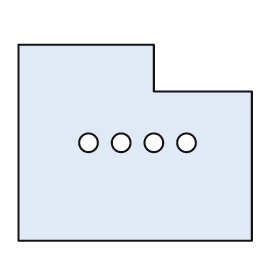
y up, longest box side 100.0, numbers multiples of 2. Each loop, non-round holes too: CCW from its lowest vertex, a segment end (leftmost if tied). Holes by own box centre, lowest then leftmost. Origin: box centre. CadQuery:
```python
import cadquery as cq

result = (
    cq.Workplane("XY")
    .moveTo(-50.0, -42.0)
    .lineTo(50.0, -42.0)
    .lineTo(50.0, 22.0)
    .lineTo(8.0, 22.0)
    .lineTo(8.0, 42.0)
    .lineTo(-50.0, 42.0)
    .close()
    .moveTo(-20.0, 0.0)
    .circle(4.0)
    .moveTo(-6.0, 0.0)
    .circle(4.0)
    .moveTo(8.0, 0.0)
    .circle(4.0)
    .moveTo(22.0, 0.0)
    .circle(4.0)
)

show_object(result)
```